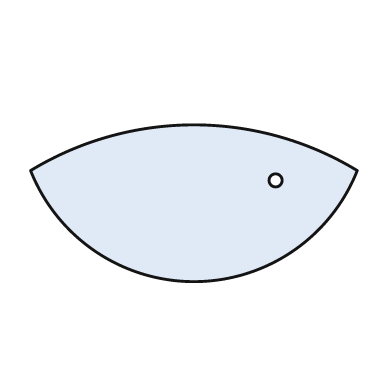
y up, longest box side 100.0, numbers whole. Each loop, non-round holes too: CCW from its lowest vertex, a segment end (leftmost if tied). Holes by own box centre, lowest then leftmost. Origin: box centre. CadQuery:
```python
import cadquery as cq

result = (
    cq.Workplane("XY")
    .moveTo(-50.0, 10.0)
    .threePointArc((0.0, -24.0), (50.0, 10.0))
    .threePointArc((0.0, 24.0), (-50.0, 10.0))
    .close()
    .moveTo(25.0, 7.0)
    .circle(2.0)
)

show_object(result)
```